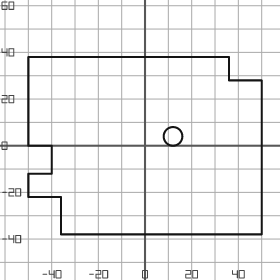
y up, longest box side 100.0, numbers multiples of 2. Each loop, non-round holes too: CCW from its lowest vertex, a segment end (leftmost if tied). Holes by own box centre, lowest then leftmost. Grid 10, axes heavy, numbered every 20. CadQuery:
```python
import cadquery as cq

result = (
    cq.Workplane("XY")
    .moveTo(-36.0, -38.0)
    .lineTo(50.0, -38.0)
    .lineTo(50.0, 28.0)
    .lineTo(36.0, 28.0)
    .lineTo(36.0, 38.0)
    .lineTo(-50.0, 38.0)
    .lineTo(-50.0, 0.0)
    .lineTo(-40.0, 0.0)
    .lineTo(-40.0, -12.0)
    .lineTo(-50.0, -12.0)
    .lineTo(-50.0, -22.0)
    .lineTo(-36.0, -22.0)
    .close()
    .moveTo(12.0, 4.0)
    .circle(4.0)
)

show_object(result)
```